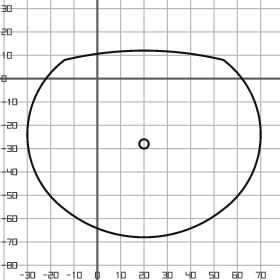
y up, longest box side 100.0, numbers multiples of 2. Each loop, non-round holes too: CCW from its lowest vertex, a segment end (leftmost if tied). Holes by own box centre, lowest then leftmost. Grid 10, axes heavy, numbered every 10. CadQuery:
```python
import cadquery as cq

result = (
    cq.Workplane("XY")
    .moveTo(-14.0, -56.0)
    .threePointArc((20.0, -68.0), (54.0, -56.0))
    .threePointArc((70.0, -24.0), (54.0, 8.0))
    .threePointArc((20.0, 12.0), (-14.0, 8.0))
    .threePointArc((-30.0, -24.0), (-14.0, -56.0))
    .close()
    .moveTo(20.0, -28.0)
    .circle(2.0)
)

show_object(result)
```